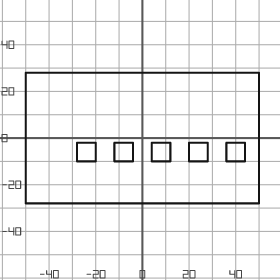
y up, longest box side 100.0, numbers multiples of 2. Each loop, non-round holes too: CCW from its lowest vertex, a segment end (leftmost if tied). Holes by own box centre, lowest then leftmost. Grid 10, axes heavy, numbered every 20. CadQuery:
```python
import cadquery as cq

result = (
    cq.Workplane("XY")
    .moveTo(-50.0, -28.0)
    .lineTo(50.0, -28.0)
    .lineTo(50.0, 28.0)
    .lineTo(-50.0, 28.0)
    .close()
    .moveTo(-28.0, -10.0)
    .lineTo(-20.0, -10.0)
    .lineTo(-20.0, -2.0)
    .lineTo(-28.0, -2.0)
    .close()
    .moveTo(-12.0, -10.0)
    .lineTo(-4.0, -10.0)
    .lineTo(-4.0, -2.0)
    .lineTo(-12.0, -2.0)
    .close()
    .moveTo(4.0, -10.0)
    .lineTo(12.0, -10.0)
    .lineTo(12.0, -2.0)
    .lineTo(4.0, -2.0)
    .close()
    .moveTo(20.0, -10.0)
    .lineTo(28.0, -10.0)
    .lineTo(28.0, -2.0)
    .lineTo(20.0, -2.0)
    .close()
    .moveTo(36.0, -10.0)
    .lineTo(44.0, -10.0)
    .lineTo(44.0, -2.0)
    .lineTo(36.0, -2.0)
    .close()
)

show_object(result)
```